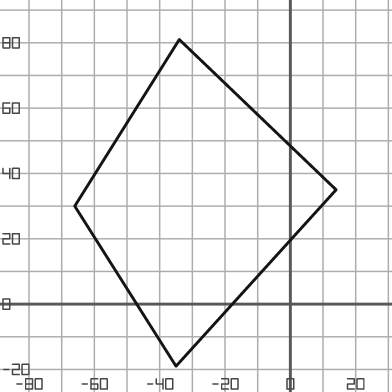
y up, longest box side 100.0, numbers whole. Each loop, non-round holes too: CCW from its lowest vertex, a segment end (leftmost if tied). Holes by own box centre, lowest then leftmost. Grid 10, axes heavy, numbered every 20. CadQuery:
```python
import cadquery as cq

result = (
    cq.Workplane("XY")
    .moveTo(-35.0, -19.0)
    .lineTo(14.0, 35.0)
    .lineTo(-34.0, 81.0)
    .lineTo(-66.0, 30.0)
    .close()
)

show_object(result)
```